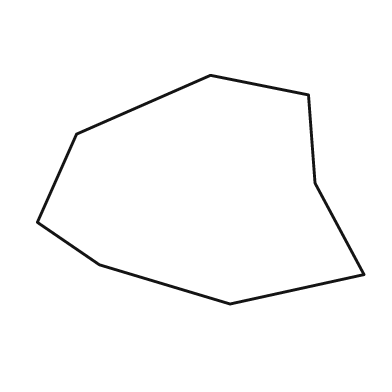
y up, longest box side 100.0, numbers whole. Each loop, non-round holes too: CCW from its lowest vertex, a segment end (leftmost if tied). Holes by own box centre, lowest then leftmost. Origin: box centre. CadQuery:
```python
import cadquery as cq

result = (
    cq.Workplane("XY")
    .moveTo(9.0, -35.0)
    .lineTo(50.0, -26.0)
    .lineTo(35.0, 2.0)
    .lineTo(33.0, 29.0)
    .lineTo(3.0, 35.0)
    .lineTo(-38.0, 17.0)
    .lineTo(-50.0, -10.0)
    .lineTo(-31.0, -23.0)
    .close()
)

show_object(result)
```